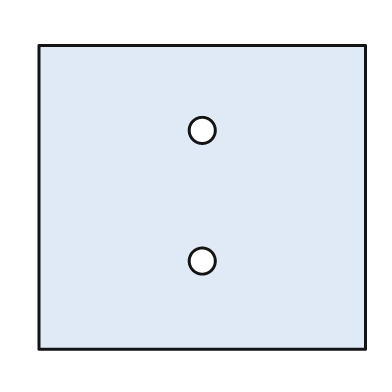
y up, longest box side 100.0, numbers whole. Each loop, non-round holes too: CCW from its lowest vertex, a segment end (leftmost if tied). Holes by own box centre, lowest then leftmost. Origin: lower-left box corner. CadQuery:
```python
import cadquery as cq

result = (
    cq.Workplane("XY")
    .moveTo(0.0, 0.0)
    .lineTo(100.0, 0.0)
    .lineTo(100.0, 93.0)
    .lineTo(0.0, 93.0)
    .close()
    .moveTo(50.0, 27.0)
    .circle(4.0)
    .moveTo(50.0, 67.0)
    .circle(4.0)
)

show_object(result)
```